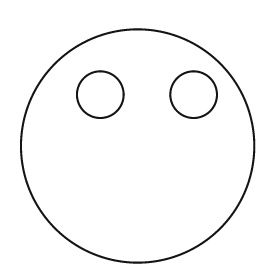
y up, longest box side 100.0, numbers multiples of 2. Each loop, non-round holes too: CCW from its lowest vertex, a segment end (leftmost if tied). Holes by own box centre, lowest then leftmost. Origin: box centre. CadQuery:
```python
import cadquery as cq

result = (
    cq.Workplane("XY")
    .moveTo(0.0, 0.0)
    .circle(50.0)
    .moveTo(-16.0, 22.0)
    .circle(10.0)
    .moveTo(24.0, 22.0)
    .circle(10.0)
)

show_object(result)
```